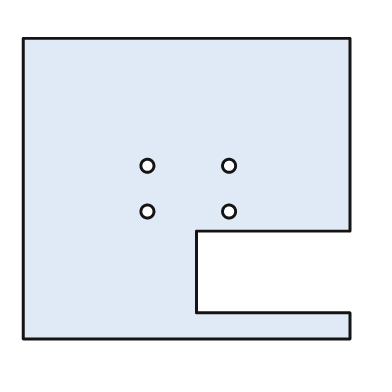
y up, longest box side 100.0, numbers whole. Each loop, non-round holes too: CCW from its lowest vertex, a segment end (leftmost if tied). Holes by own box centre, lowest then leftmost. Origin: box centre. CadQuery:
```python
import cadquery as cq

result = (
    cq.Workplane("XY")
    .moveTo(-50.0, -46.0)
    .lineTo(50.0, -46.0)
    .lineTo(50.0, -38.0)
    .lineTo(3.0, -38.0)
    .lineTo(3.0, -13.0)
    .lineTo(50.0, -13.0)
    .lineTo(50.0, 46.0)
    .lineTo(-50.0, 46.0)
    .close()
    .moveTo(-12.0, -7.0)
    .circle(2.0)
    .moveTo(13.0, -7.0)
    .circle(2.0)
    .moveTo(-12.0, 7.0)
    .circle(2.0)
    .moveTo(13.0, 7.0)
    .circle(2.0)
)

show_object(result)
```